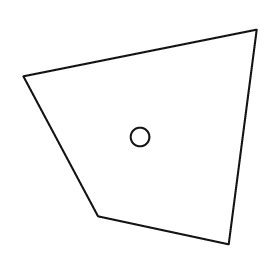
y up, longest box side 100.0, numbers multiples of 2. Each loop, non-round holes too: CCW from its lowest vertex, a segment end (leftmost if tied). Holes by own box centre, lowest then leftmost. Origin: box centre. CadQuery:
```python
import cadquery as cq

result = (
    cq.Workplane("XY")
    .moveTo(38.0, -46.0)
    .lineTo(50.0, 46.0)
    .lineTo(-50.0, 26.0)
    .lineTo(-18.0, -34.0)
    .close()
    .moveTo(0.0, 0.0)
    .circle(4.0)
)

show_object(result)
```